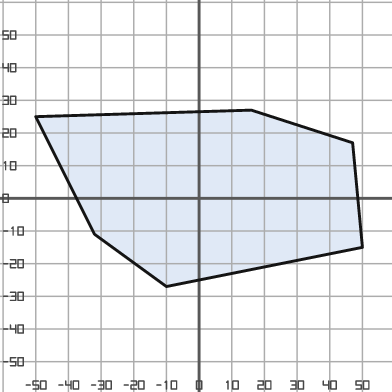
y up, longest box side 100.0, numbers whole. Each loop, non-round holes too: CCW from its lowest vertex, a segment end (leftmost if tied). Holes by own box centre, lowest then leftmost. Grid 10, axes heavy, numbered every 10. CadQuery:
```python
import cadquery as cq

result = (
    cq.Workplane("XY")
    .moveTo(-10.0, -27.0)
    .lineTo(50.0, -15.0)
    .lineTo(47.0, 17.0)
    .lineTo(16.0, 27.0)
    .lineTo(-50.0, 25.0)
    .lineTo(-32.0, -11.0)
    .close()
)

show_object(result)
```